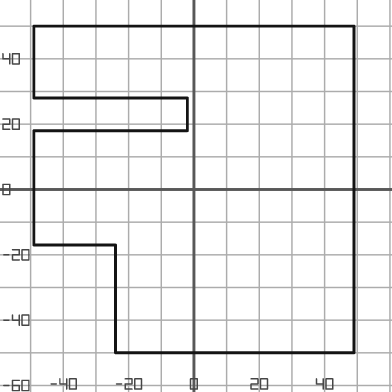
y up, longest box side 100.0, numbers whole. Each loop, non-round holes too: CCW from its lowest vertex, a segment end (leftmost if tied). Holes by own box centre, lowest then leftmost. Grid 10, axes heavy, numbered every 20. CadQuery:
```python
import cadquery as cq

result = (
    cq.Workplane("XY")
    .moveTo(-24.0, -50.0)
    .lineTo(49.0, -50.0)
    .lineTo(49.0, 50.0)
    .lineTo(-49.0, 50.0)
    .lineTo(-49.0, 28.0)
    .lineTo(-2.0, 28.0)
    .lineTo(-2.0, 18.0)
    .lineTo(-49.0, 18.0)
    .lineTo(-49.0, -17.0)
    .lineTo(-24.0, -17.0)
    .close()
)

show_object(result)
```